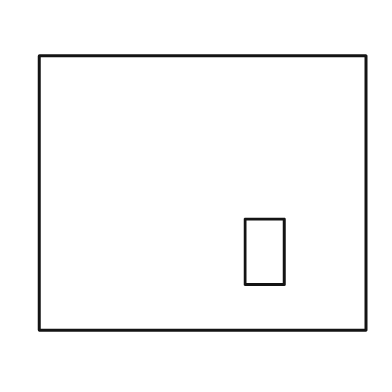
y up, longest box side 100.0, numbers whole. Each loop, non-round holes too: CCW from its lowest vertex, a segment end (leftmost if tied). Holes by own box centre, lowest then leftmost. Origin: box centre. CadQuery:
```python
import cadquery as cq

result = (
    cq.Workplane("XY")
    .moveTo(-50.0, -42.0)
    .lineTo(50.0, -42.0)
    .lineTo(50.0, 42.0)
    .lineTo(-50.0, 42.0)
    .close()
    .moveTo(13.0, -28.0)
    .lineTo(25.0, -28.0)
    .lineTo(25.0, -8.0)
    .lineTo(13.0, -8.0)
    .close()
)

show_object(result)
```